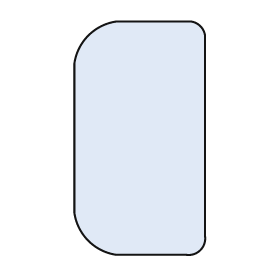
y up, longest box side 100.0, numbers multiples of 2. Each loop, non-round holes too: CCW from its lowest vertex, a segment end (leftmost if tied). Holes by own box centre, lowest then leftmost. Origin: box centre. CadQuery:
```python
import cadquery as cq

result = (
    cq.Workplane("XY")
    .moveTo(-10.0, -50.0)
    .lineTo(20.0, -50.0)
    .threePointArc((26.0, -48.0), (28.0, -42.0))
    .lineTo(28.0, 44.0)
    .threePointArc((26.0, 48.0), (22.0, 50.0))
    .lineTo(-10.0, 50.0)
    .threePointArc((-22.0, 44.0), (-28.0, 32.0))
    .lineTo(-28.0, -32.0)
    .threePointArc((-22.0, -44.0), (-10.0, -50.0))
    .close()
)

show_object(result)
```